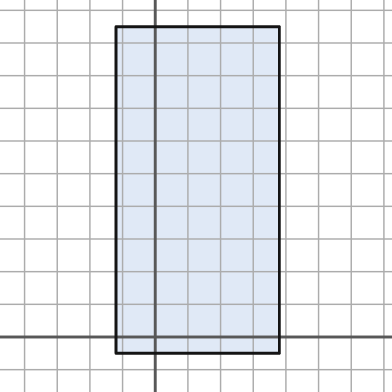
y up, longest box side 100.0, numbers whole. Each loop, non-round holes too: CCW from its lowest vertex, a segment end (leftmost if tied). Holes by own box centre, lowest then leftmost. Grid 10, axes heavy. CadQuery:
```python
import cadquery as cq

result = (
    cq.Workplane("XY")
    .moveTo(-12.0, -5.0)
    .lineTo(38.0, -5.0)
    .lineTo(38.0, 95.0)
    .lineTo(-12.0, 95.0)
    .close()
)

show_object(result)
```